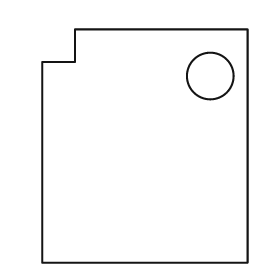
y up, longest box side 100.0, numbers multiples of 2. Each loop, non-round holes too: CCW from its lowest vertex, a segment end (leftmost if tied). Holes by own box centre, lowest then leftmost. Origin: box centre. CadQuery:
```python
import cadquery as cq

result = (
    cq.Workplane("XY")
    .moveTo(-44.0, -50.0)
    .lineTo(44.0, -50.0)
    .lineTo(44.0, 50.0)
    .lineTo(-30.0, 50.0)
    .lineTo(-30.0, 36.0)
    .lineTo(-44.0, 36.0)
    .close()
    .moveTo(28.0, 30.0)
    .circle(10.0)
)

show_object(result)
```